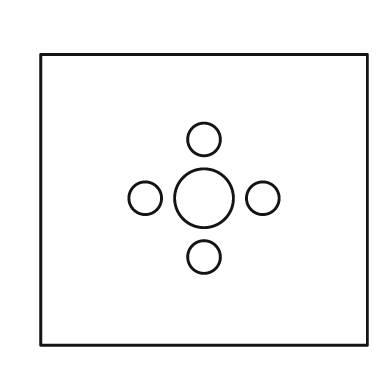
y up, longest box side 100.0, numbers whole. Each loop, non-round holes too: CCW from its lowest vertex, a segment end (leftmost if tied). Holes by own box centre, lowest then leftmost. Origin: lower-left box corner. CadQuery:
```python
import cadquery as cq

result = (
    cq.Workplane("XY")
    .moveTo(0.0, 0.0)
    .lineTo(100.0, 0.0)
    .lineTo(100.0, 89.0)
    .lineTo(0.0, 89.0)
    .close()
    .moveTo(50.0, 27.0)
    .circle(5.0)
    .moveTo(32.0, 45.0)
    .circle(5.0)
    .moveTo(50.0, 45.0)
    .circle(9.0)
    .moveTo(68.0, 45.0)
    .circle(5.0)
    .moveTo(50.0, 63.0)
    .circle(5.0)
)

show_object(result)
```